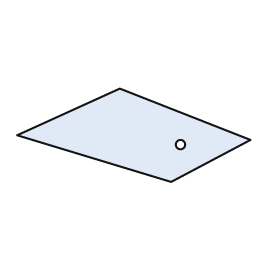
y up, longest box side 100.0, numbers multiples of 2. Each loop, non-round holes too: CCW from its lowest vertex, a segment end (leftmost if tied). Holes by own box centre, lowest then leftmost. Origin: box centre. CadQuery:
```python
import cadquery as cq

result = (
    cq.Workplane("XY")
    .moveTo(16.0, -20.0)
    .lineTo(50.0, -2.0)
    .lineTo(-6.0, 20.0)
    .lineTo(-50.0, 0.0)
    .close()
    .moveTo(20.0, -4.0)
    .circle(2.0)
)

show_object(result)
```